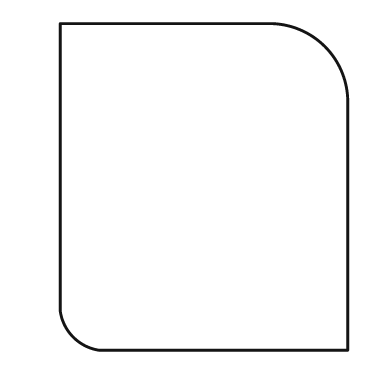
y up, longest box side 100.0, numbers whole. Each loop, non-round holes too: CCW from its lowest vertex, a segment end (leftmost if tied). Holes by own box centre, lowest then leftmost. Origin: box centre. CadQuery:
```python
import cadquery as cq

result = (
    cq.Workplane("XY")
    .moveTo(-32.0, -50.0)
    .lineTo(44.0, -50.0)
    .lineTo(44.0, 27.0)
    .threePointArc((37.0, 43.0), (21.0, 50.0))
    .lineTo(-44.0, 50.0)
    .lineTo(-44.0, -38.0)
    .threePointArc((-40.0, -46.0), (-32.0, -50.0))
    .close()
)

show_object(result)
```